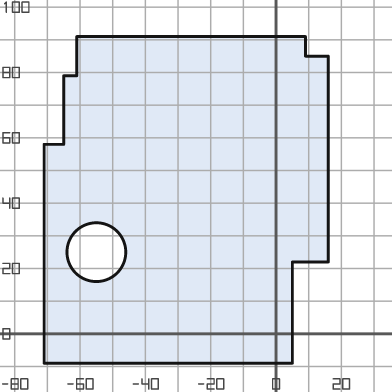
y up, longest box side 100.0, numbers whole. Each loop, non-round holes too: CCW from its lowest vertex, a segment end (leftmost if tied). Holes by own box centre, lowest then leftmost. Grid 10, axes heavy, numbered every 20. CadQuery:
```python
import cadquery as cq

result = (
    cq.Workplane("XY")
    .moveTo(-71.0, -9.0)
    .lineTo(5.0, -9.0)
    .lineTo(5.0, 22.0)
    .lineTo(16.0, 22.0)
    .lineTo(16.0, 85.0)
    .lineTo(9.0, 85.0)
    .lineTo(9.0, 91.0)
    .lineTo(-61.0, 91.0)
    .lineTo(-61.0, 79.0)
    .lineTo(-65.0, 79.0)
    .lineTo(-65.0, 58.0)
    .lineTo(-71.0, 58.0)
    .close()
    .moveTo(-55.0, 25.0)
    .circle(9.0)
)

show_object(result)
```